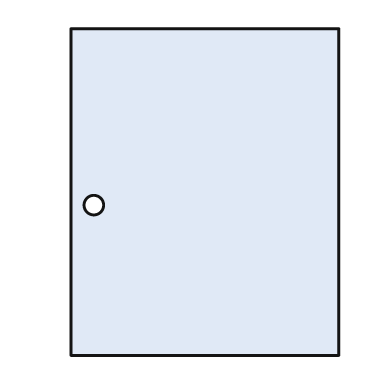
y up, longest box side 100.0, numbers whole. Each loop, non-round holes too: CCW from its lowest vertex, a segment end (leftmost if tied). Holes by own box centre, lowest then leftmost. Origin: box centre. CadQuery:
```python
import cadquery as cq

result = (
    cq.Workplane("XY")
    .moveTo(-41.0, -50.0)
    .lineTo(41.0, -50.0)
    .lineTo(41.0, 50.0)
    .lineTo(-41.0, 50.0)
    .close()
    .moveTo(-34.0, -4.0)
    .circle(3.0)
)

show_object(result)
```